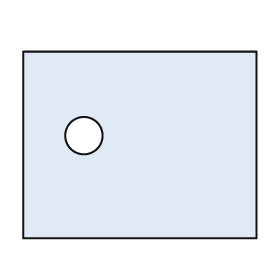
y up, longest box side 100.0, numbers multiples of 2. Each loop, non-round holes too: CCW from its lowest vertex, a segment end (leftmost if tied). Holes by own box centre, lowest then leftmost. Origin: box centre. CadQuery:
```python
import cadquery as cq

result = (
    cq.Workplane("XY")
    .moveTo(-50.0, -40.0)
    .lineTo(50.0, -40.0)
    .lineTo(50.0, 40.0)
    .lineTo(-50.0, 40.0)
    .close()
    .moveTo(-24.0, 4.0)
    .circle(8.0)
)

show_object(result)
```